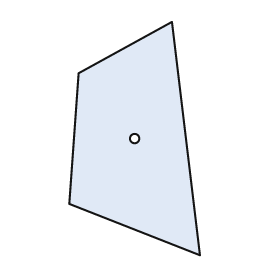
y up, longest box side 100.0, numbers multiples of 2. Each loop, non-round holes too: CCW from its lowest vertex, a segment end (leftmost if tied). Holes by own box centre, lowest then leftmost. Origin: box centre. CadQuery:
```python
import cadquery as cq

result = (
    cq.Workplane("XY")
    .moveTo(28.0, -50.0)
    .lineTo(16.0, 50.0)
    .lineTo(-24.0, 28.0)
    .lineTo(-28.0, -28.0)
    .close()
    .moveTo(0.0, 0.0)
    .circle(2.0)
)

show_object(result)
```